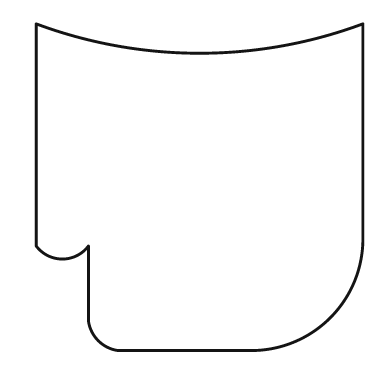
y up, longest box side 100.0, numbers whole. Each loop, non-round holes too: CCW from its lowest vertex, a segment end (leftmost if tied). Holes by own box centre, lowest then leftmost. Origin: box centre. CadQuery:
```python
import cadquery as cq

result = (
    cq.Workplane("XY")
    .moveTo(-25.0, -50.0)
    .lineTo(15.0, -50.0)
    .threePointArc((40.0, -40.0), (50.0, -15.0))
    .lineTo(50.0, 50.0)
    .threePointArc((0.0, 41.0), (-50.0, 50.0))
    .lineTo(-50.0, -18.0)
    .threePointArc((-42.0, -22.0), (-34.0, -18.0))
    .lineTo(-34.0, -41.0)
    .threePointArc((-31.0, -47.0), (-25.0, -50.0))
    .close()
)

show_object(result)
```